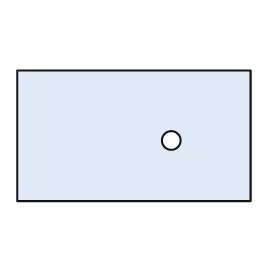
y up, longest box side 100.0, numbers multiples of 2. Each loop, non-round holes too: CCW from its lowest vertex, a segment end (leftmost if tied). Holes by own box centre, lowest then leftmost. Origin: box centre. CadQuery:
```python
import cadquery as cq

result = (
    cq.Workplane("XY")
    .moveTo(-50.0, -28.0)
    .lineTo(50.0, -28.0)
    .lineTo(50.0, 28.0)
    .lineTo(-50.0, 28.0)
    .close()
    .moveTo(16.0, -2.0)
    .circle(4.0)
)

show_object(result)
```